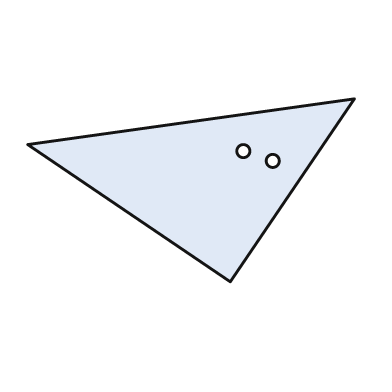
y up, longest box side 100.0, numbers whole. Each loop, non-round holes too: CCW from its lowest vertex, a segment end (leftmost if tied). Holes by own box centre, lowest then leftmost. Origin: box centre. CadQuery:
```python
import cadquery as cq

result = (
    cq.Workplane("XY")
    .moveTo(12.0, -28.0)
    .lineTo(50.0, 28.0)
    .lineTo(-50.0, 14.0)
    .close()
    .moveTo(25.0, 9.0)
    .circle(2.0)
    .moveTo(16.0, 12.0)
    .circle(2.0)
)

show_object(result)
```